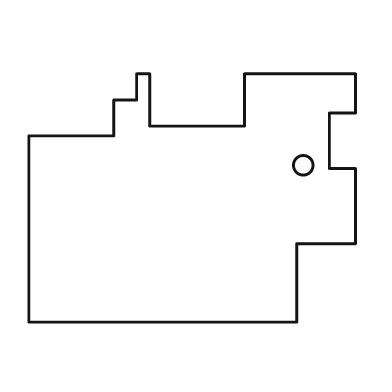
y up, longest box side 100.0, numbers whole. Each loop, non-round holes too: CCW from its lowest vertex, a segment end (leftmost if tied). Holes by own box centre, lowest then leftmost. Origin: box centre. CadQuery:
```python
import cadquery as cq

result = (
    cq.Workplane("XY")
    .moveTo(-50.0, -38.0)
    .lineTo(32.0, -38.0)
    .lineTo(32.0, -14.0)
    .lineTo(50.0, -14.0)
    .lineTo(50.0, 9.0)
    .lineTo(42.0, 9.0)
    .lineTo(42.0, 26.0)
    .lineTo(50.0, 26.0)
    .lineTo(50.0, 38.0)
    .lineTo(16.0, 38.0)
    .lineTo(16.0, 22.0)
    .lineTo(-13.0, 22.0)
    .lineTo(-13.0, 38.0)
    .lineTo(-17.0, 38.0)
    .lineTo(-17.0, 30.0)
    .lineTo(-24.0, 30.0)
    .lineTo(-24.0, 19.0)
    .lineTo(-50.0, 19.0)
    .close()
    .moveTo(34.0, 10.0)
    .circle(3.0)
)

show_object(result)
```